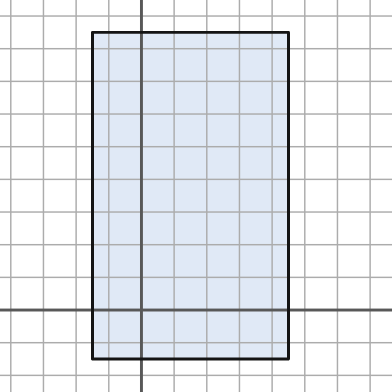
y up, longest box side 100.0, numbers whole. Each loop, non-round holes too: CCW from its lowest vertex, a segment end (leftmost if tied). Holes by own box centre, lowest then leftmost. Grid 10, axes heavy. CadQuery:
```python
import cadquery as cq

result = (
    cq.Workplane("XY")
    .moveTo(-15.0, -15.0)
    .lineTo(45.0, -15.0)
    .lineTo(45.0, 85.0)
    .lineTo(-15.0, 85.0)
    .close()
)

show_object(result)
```